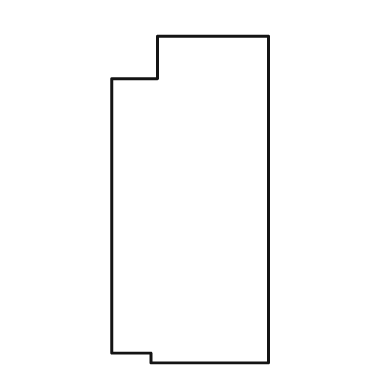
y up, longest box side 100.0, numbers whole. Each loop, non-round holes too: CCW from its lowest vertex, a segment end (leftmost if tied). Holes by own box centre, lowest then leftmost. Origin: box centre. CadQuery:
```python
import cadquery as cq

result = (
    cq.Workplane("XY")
    .moveTo(-12.0, -50.0)
    .lineTo(24.0, -50.0)
    .lineTo(24.0, 50.0)
    .lineTo(-10.0, 50.0)
    .lineTo(-10.0, 37.0)
    .lineTo(-24.0, 37.0)
    .lineTo(-24.0, -47.0)
    .lineTo(-12.0, -47.0)
    .close()
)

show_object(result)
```